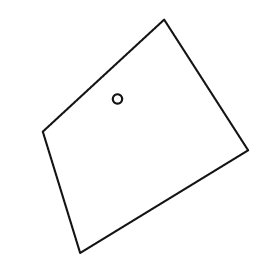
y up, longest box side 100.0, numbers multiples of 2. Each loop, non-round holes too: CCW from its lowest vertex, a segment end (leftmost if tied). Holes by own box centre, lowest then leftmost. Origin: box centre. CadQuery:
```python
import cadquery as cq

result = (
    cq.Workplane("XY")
    .moveTo(-28.0, -50.0)
    .lineTo(44.0, -6.0)
    .lineTo(8.0, 50.0)
    .lineTo(-44.0, 2.0)
    .close()
    .moveTo(-12.0, 16.0)
    .circle(2.0)
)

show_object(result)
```